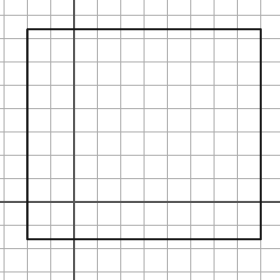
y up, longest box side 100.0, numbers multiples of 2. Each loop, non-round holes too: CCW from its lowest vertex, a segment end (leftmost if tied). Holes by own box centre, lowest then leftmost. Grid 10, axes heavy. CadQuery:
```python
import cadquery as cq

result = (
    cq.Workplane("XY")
    .moveTo(-20.0, -16.0)
    .lineTo(80.0, -16.0)
    .lineTo(80.0, 74.0)
    .lineTo(-20.0, 74.0)
    .close()
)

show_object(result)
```